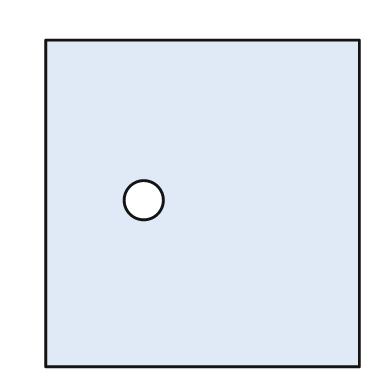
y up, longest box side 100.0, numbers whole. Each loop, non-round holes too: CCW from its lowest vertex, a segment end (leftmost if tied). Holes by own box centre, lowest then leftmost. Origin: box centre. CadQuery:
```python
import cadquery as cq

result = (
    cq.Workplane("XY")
    .moveTo(-48.0, -50.0)
    .lineTo(48.0, -50.0)
    .lineTo(48.0, 50.0)
    .lineTo(-48.0, 50.0)
    .close()
    .moveTo(-18.0, 1.0)
    .circle(6.0)
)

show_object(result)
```